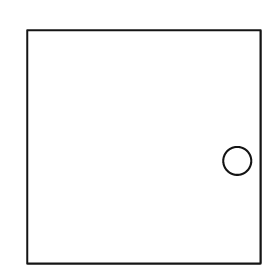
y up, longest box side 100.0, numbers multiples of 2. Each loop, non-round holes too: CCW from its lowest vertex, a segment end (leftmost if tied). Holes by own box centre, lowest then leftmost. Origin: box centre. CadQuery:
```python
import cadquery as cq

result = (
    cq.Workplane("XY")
    .moveTo(-50.0, -50.0)
    .lineTo(50.0, -50.0)
    .lineTo(50.0, 50.0)
    .lineTo(-50.0, 50.0)
    .close()
    .moveTo(40.0, -6.0)
    .circle(6.0)
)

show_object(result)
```